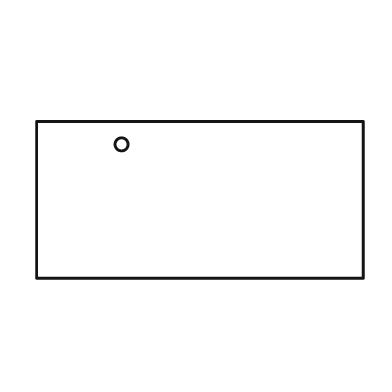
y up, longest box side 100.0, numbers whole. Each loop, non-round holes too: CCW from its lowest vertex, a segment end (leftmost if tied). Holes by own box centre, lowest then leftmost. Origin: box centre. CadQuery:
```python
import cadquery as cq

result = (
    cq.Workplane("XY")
    .moveTo(-50.0, -24.0)
    .lineTo(50.0, -24.0)
    .lineTo(50.0, 24.0)
    .lineTo(-50.0, 24.0)
    .close()
    .moveTo(-24.0, 17.0)
    .circle(2.0)
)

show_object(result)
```